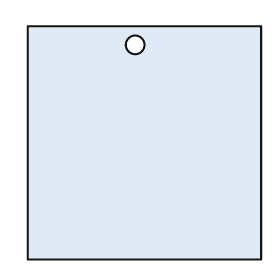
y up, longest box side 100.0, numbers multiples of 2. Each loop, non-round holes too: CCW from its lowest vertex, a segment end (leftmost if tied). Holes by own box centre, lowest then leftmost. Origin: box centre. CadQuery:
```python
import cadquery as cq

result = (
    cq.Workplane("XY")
    .moveTo(-50.0, -50.0)
    .lineTo(50.0, -50.0)
    .lineTo(50.0, 50.0)
    .lineTo(-50.0, 50.0)
    .close()
    .moveTo(-4.0, 42.0)
    .circle(4.0)
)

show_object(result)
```